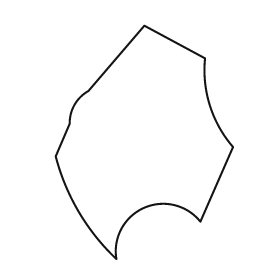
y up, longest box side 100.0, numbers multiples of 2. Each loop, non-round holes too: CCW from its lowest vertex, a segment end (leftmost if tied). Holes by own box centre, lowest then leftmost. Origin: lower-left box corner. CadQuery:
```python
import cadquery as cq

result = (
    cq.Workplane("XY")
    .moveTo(26.0, 0.0)
    .threePointArc((38.0, 22.0), (62.0, 16.0))
    .lineTo(76.0, 48.0)
    .threePointArc((66.0, 66.0), (64.0, 86.0))
    .lineTo(38.0, 100.0)
    .lineTo(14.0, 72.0)
    .threePointArc((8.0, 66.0), (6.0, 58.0))
    .lineTo(0.0, 44.0)
    .threePointArc((10.0, 20.0), (26.0, 0.0))
    .close()
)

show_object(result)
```